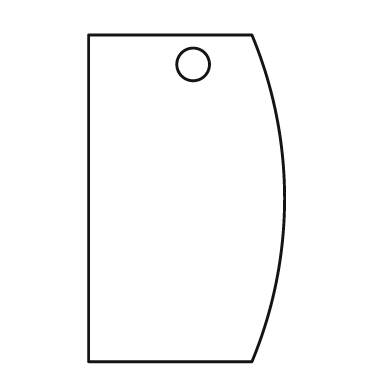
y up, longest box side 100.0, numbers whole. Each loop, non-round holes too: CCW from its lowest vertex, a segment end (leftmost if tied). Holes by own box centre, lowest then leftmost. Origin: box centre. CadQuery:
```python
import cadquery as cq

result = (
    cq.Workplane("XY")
    .moveTo(-30.0, -50.0)
    .lineTo(20.0, -50.0)
    .threePointArc((30.0, 0.0), (20.0, 50.0))
    .lineTo(-30.0, 50.0)
    .close()
    .moveTo(2.0, 41.0)
    .circle(5.0)
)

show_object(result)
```